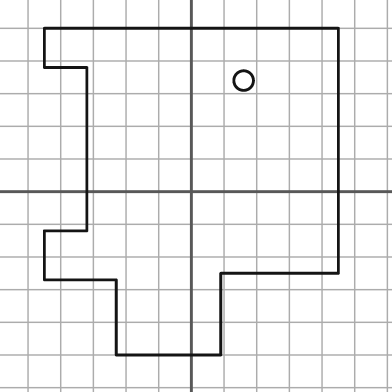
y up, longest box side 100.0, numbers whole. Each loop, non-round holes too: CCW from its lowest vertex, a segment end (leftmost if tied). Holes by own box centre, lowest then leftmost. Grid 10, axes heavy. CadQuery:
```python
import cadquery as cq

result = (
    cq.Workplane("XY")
    .moveTo(-23.0, -50.0)
    .lineTo(9.0, -50.0)
    .lineTo(9.0, -25.0)
    .lineTo(45.0, -25.0)
    .lineTo(45.0, 50.0)
    .lineTo(-45.0, 50.0)
    .lineTo(-45.0, 38.0)
    .lineTo(-32.0, 38.0)
    .lineTo(-32.0, -12.0)
    .lineTo(-45.0, -12.0)
    .lineTo(-45.0, -27.0)
    .lineTo(-23.0, -27.0)
    .close()
    .moveTo(16.0, 34.0)
    .circle(3.0)
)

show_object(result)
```